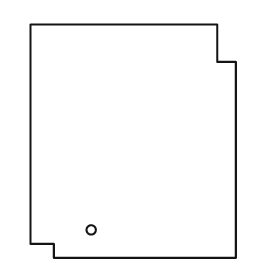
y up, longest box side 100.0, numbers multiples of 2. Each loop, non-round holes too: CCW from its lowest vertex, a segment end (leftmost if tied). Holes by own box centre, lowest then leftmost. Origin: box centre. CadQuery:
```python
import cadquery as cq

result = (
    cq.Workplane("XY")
    .moveTo(-34.0, -50.0)
    .lineTo(44.0, -50.0)
    .lineTo(44.0, 34.0)
    .lineTo(36.0, 34.0)
    .lineTo(36.0, 50.0)
    .lineTo(-44.0, 50.0)
    .lineTo(-44.0, -44.0)
    .lineTo(-34.0, -44.0)
    .close()
    .moveTo(-18.0, -38.0)
    .circle(2.0)
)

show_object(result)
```